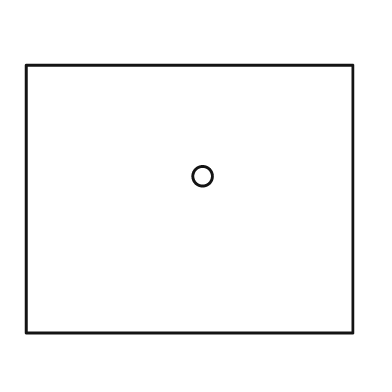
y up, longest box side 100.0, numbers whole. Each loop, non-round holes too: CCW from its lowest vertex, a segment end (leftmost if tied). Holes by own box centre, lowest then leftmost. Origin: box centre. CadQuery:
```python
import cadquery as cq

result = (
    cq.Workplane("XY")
    .moveTo(-50.0, -41.0)
    .lineTo(50.0, -41.0)
    .lineTo(50.0, 41.0)
    .lineTo(-50.0, 41.0)
    .close()
    .moveTo(4.0, 7.0)
    .circle(3.0)
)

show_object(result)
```